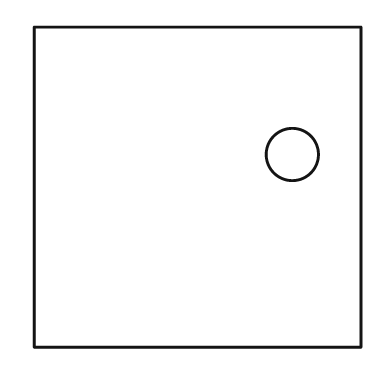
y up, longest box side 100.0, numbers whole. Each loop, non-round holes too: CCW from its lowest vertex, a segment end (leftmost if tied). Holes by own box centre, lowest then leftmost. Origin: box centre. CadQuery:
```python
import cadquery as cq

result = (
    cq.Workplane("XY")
    .moveTo(-50.0, -49.0)
    .lineTo(50.0, -49.0)
    .lineTo(50.0, 49.0)
    .lineTo(-50.0, 49.0)
    .close()
    .moveTo(29.0, 10.0)
    .circle(8.0)
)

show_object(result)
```